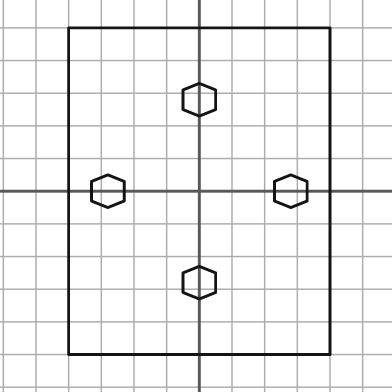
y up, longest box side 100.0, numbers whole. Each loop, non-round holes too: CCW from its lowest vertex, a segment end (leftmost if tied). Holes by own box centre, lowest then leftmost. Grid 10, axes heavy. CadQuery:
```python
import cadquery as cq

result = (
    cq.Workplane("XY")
    .moveTo(-40.0, -50.0)
    .lineTo(40.0, -50.0)
    .lineTo(40.0, 50.0)
    .lineTo(-40.0, 50.0)
    .close()
    .moveTo(0.0, -33.0)
    .lineTo(5.0, -31.0)
    .lineTo(5.0, -25.0)
    .lineTo(0.0, -23.0)
    .lineTo(-5.0, -25.0)
    .lineTo(-5.0, -31.0)
    .close()
    .moveTo(-28.0, -5.0)
    .lineTo(-23.0, -3.0)
    .lineTo(-23.0, 3.0)
    .lineTo(-28.0, 5.0)
    .lineTo(-33.0, 3.0)
    .lineTo(-33.0, -3.0)
    .close()
    .moveTo(28.0, -5.0)
    .lineTo(33.0, -3.0)
    .lineTo(33.0, 3.0)
    .lineTo(28.0, 5.0)
    .lineTo(23.0, 3.0)
    .lineTo(23.0, -3.0)
    .close()
    .moveTo(0.0, 23.0)
    .lineTo(5.0, 25.0)
    .lineTo(5.0, 31.0)
    .lineTo(0.0, 33.0)
    .lineTo(-5.0, 31.0)
    .lineTo(-5.0, 25.0)
    .close()
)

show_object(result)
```